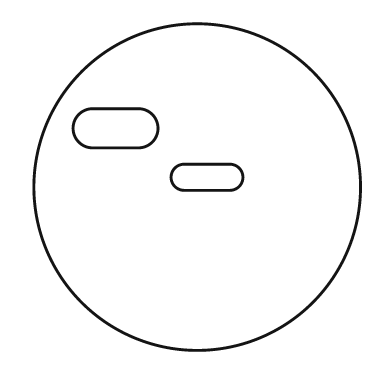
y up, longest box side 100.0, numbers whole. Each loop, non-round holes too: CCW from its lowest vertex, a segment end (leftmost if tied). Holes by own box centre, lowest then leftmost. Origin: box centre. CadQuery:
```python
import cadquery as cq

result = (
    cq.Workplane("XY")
    .moveTo(0.0, 0.0)
    .circle(50.0)
    .moveTo(-4.0, -1.0)
    .lineTo(10.0, -1.0)
    .threePointArc((14.0, 3.0), (10.0, 7.0))
    .lineTo(-4.0, 7.0)
    .threePointArc((-8.0, 3.0), (-4.0, -1.0))
    .close()
    .moveTo(-32.0, 12.0)
    .lineTo(-18.0, 12.0)
    .threePointArc((-12.0, 18.0), (-18.0, 24.0))
    .lineTo(-32.0, 24.0)
    .threePointArc((-38.0, 18.0), (-32.0, 12.0))
    .close()
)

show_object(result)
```